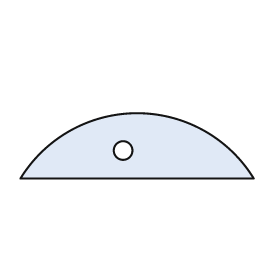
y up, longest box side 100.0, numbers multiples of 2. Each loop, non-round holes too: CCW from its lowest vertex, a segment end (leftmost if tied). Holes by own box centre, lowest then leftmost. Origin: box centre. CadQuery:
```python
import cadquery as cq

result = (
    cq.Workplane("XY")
    .moveTo(-50.0, -14.0)
    .lineTo(50.0, -14.0)
    .threePointArc((0.0, 14.0), (-50.0, -14.0))
    .close()
    .moveTo(-6.0, -2.0)
    .circle(4.0)
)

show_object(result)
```